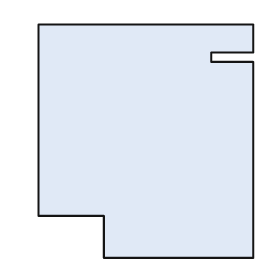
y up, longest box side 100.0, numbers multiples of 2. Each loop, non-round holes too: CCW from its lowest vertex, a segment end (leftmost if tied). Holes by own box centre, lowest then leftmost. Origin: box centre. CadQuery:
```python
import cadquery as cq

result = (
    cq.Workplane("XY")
    .moveTo(-18.0, -50.0)
    .lineTo(46.0, -50.0)
    .lineTo(46.0, 34.0)
    .lineTo(28.0, 34.0)
    .lineTo(28.0, 38.0)
    .lineTo(46.0, 38.0)
    .lineTo(46.0, 50.0)
    .lineTo(-46.0, 50.0)
    .lineTo(-46.0, -32.0)
    .lineTo(-18.0, -32.0)
    .close()
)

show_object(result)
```